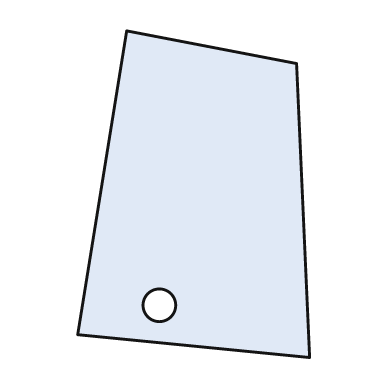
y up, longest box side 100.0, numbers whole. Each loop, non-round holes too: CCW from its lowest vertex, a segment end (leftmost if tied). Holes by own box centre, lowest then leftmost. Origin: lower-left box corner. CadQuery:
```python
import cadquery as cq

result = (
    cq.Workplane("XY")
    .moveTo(71.0, 0.0)
    .lineTo(67.0, 90.0)
    .lineTo(15.0, 100.0)
    .lineTo(0.0, 7.0)
    .close()
    .moveTo(25.0, 16.0)
    .circle(5.0)
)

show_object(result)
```